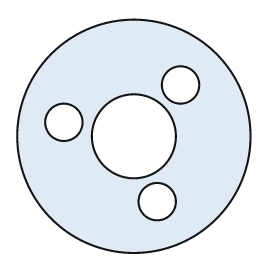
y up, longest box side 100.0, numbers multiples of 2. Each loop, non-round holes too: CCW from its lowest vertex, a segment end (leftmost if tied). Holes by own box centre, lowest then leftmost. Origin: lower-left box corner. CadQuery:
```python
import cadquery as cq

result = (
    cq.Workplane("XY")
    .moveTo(50.0, 50.0)
    .circle(50.0)
    .moveTo(60.0, 22.0)
    .circle(8.0)
    .moveTo(50.0, 50.0)
    .circle(18.0)
    .moveTo(20.0, 56.0)
    .circle(8.0)
    .moveTo(70.0, 72.0)
    .circle(8.0)
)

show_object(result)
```